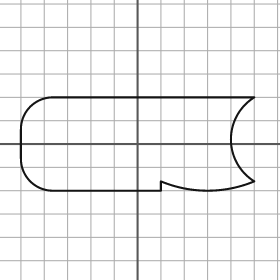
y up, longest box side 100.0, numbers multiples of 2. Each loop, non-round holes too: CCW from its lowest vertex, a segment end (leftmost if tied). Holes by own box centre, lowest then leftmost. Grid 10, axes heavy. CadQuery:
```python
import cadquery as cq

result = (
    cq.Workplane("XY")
    .moveTo(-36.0, -20.0)
    .lineTo(10.0, -20.0)
    .lineTo(10.0, -16.0)
    .threePointArc((30.0, -20.0), (50.0, -16.0))
    .threePointArc((40.0, 2.0), (50.0, 20.0))
    .lineTo(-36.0, 20.0)
    .threePointArc((-46.0, 16.0), (-50.0, 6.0))
    .lineTo(-50.0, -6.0)
    .threePointArc((-46.0, -16.0), (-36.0, -20.0))
    .close()
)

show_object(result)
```